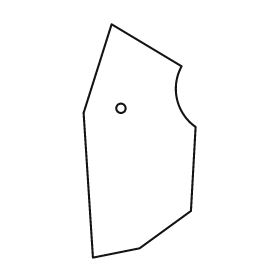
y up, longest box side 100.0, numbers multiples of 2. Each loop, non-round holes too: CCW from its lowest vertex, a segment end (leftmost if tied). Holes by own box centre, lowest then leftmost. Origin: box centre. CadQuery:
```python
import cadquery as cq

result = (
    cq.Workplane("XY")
    .moveTo(-20.0, -50.0)
    .lineTo(0.0, -46.0)
    .lineTo(22.0, -30.0)
    .lineTo(24.0, 6.0)
    .threePointArc((16.0, 18.0), (18.0, 32.0))
    .lineTo(-12.0, 50.0)
    .lineTo(-24.0, 12.0)
    .close()
    .moveTo(-8.0, 14.0)
    .circle(2.0)
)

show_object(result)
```